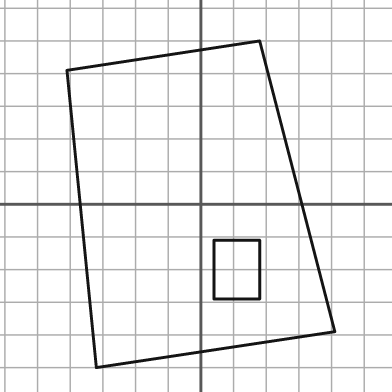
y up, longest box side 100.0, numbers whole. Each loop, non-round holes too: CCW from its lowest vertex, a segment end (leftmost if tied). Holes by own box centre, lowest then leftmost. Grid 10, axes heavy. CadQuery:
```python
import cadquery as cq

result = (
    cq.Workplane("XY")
    .moveTo(-32.0, -50.0)
    .lineTo(41.0, -39.0)
    .lineTo(18.0, 50.0)
    .lineTo(-41.0, 41.0)
    .close()
    .moveTo(4.0, -29.0)
    .lineTo(18.0, -29.0)
    .lineTo(18.0, -11.0)
    .lineTo(4.0, -11.0)
    .close()
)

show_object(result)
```